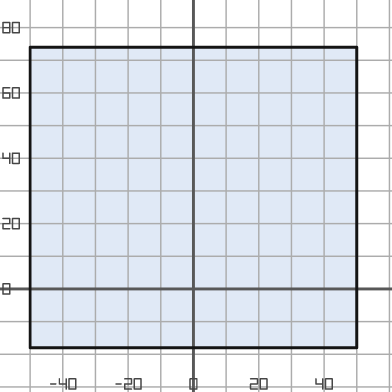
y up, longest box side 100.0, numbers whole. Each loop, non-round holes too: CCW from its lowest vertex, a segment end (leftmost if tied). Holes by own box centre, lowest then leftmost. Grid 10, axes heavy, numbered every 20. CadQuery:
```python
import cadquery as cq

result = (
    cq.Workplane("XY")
    .moveTo(-50.0, -18.0)
    .lineTo(50.0, -18.0)
    .lineTo(50.0, 74.0)
    .lineTo(-50.0, 74.0)
    .close()
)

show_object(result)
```